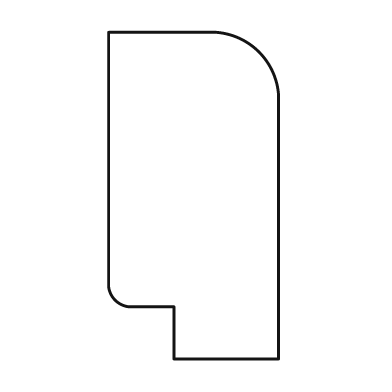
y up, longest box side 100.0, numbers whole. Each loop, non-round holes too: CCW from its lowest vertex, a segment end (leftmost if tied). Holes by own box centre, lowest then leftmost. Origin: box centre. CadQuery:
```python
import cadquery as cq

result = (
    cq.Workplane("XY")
    .moveTo(-6.0, -50.0)
    .lineTo(26.0, -50.0)
    .lineTo(26.0, 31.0)
    .threePointArc((20.0, 44.0), (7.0, 50.0))
    .lineTo(-26.0, 50.0)
    .lineTo(-26.0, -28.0)
    .threePointArc((-24.0, -32.0), (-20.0, -34.0))
    .lineTo(-6.0, -34.0)
    .close()
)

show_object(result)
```